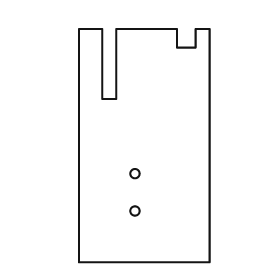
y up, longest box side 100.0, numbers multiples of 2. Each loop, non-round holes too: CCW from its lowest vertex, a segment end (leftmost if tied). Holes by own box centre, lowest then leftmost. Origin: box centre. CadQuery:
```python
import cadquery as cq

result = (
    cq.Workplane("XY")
    .moveTo(-28.0, -50.0)
    .lineTo(28.0, -50.0)
    .lineTo(28.0, 50.0)
    .lineTo(22.0, 50.0)
    .lineTo(22.0, 42.0)
    .lineTo(14.0, 42.0)
    .lineTo(14.0, 50.0)
    .lineTo(-12.0, 50.0)
    .lineTo(-12.0, 20.0)
    .lineTo(-18.0, 20.0)
    .lineTo(-18.0, 50.0)
    .lineTo(-28.0, 50.0)
    .close()
    .moveTo(-4.0, -28.0)
    .circle(2.0)
    .moveTo(-4.0, -12.0)
    .circle(2.0)
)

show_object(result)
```